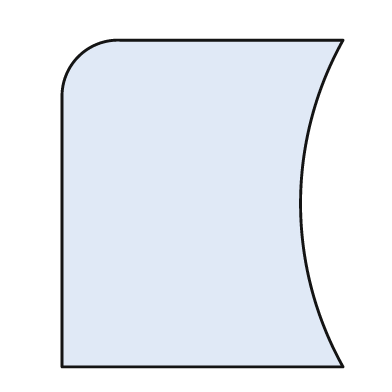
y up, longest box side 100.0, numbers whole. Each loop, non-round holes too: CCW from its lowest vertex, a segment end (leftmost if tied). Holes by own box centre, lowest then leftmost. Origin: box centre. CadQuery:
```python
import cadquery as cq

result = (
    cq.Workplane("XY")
    .moveTo(-43.0, -50.0)
    .lineTo(43.0, -50.0)
    .threePointArc((30.0, 0.0), (43.0, 50.0))
    .lineTo(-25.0, 50.0)
    .threePointArc((-38.0, 45.0), (-43.0, 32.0))
    .close()
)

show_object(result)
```